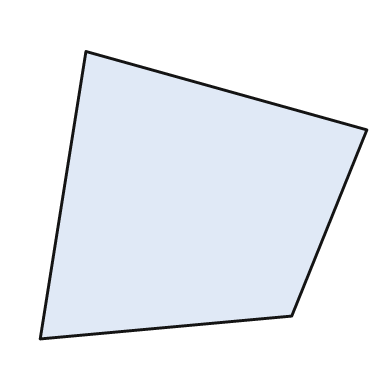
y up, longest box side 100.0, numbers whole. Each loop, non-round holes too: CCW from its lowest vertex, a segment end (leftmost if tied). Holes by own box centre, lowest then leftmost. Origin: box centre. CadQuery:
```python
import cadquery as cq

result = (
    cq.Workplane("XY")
    .moveTo(-50.0, -44.0)
    .lineTo(27.0, -37.0)
    .lineTo(50.0, 20.0)
    .lineTo(-36.0, 44.0)
    .close()
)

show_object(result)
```